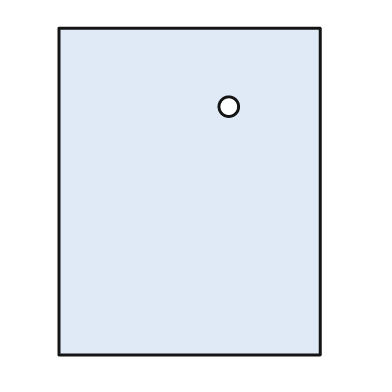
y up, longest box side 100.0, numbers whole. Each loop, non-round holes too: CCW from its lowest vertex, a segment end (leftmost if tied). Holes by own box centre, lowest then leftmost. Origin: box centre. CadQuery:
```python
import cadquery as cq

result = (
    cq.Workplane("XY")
    .moveTo(-40.0, -50.0)
    .lineTo(40.0, -50.0)
    .lineTo(40.0, 50.0)
    .lineTo(-40.0, 50.0)
    .close()
    .moveTo(12.0, 26.0)
    .circle(3.0)
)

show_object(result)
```